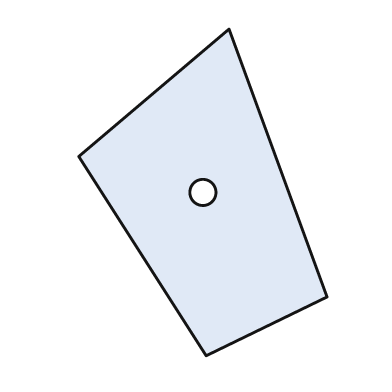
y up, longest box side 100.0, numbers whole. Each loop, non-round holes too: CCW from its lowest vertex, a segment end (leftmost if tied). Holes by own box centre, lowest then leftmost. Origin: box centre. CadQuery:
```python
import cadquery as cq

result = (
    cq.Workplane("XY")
    .moveTo(1.0, -50.0)
    .lineTo(38.0, -32.0)
    .lineTo(8.0, 50.0)
    .lineTo(-38.0, 11.0)
    .close()
    .moveTo(0.0, 0.0)
    .circle(4.0)
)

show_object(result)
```